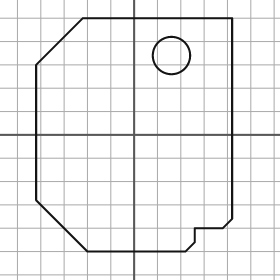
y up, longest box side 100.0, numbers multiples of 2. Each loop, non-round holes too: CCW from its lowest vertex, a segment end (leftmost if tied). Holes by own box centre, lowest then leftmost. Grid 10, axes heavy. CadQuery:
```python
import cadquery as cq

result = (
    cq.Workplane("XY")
    .moveTo(-20.0, -50.0)
    .lineTo(22.0, -50.0)
    .lineTo(26.0, -46.0)
    .lineTo(26.0, -40.0)
    .lineTo(38.0, -40.0)
    .lineTo(42.0, -36.0)
    .lineTo(42.0, 50.0)
    .lineTo(-22.0, 50.0)
    .lineTo(-42.0, 30.0)
    .lineTo(-42.0, -28.0)
    .close()
    .moveTo(16.0, 34.0)
    .circle(8.0)
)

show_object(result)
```